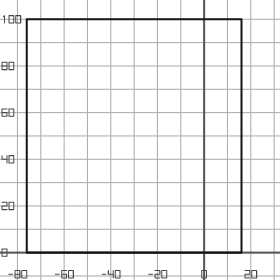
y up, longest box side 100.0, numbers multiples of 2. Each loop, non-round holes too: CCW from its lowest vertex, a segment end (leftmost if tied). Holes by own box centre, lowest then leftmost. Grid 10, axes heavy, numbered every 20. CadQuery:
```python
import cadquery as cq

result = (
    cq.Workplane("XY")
    .moveTo(-76.0, 0.0)
    .lineTo(16.0, 0.0)
    .lineTo(16.0, 100.0)
    .lineTo(-76.0, 100.0)
    .close()
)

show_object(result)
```